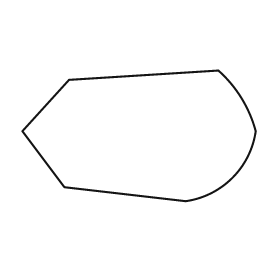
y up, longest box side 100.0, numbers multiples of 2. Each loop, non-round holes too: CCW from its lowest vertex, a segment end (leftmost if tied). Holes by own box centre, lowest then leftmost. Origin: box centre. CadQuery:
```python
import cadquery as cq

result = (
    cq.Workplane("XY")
    .moveTo(20.0, -28.0)
    .threePointArc((40.0, -18.0), (50.0, 2.0))
    .threePointArc((44.0, 16.0), (34.0, 28.0))
    .lineTo(-30.0, 24.0)
    .lineTo(-50.0, 2.0)
    .lineTo(-32.0, -22.0)
    .close()
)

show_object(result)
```